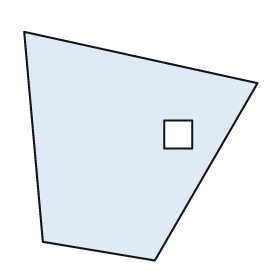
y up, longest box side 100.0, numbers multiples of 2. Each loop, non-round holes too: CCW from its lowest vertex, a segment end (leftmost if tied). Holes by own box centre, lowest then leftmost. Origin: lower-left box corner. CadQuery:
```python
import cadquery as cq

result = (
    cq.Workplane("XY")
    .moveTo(56.0, 0.0)
    .lineTo(100.0, 76.0)
    .lineTo(0.0, 98.0)
    .lineTo(8.0, 8.0)
    .close()
    .moveTo(60.0, 48.0)
    .lineTo(72.0, 48.0)
    .lineTo(72.0, 60.0)
    .lineTo(60.0, 60.0)
    .close()
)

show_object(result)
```